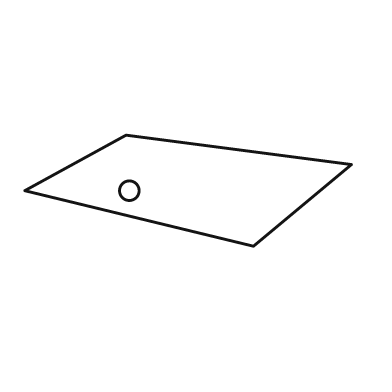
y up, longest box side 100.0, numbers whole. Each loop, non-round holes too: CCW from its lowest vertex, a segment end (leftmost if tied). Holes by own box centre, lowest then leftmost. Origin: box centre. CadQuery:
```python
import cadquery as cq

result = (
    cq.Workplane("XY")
    .moveTo(20.0, -17.0)
    .lineTo(50.0, 8.0)
    .lineTo(-19.0, 17.0)
    .lineTo(-50.0, 0.0)
    .close()
    .moveTo(-18.0, 0.0)
    .circle(3.0)
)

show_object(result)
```